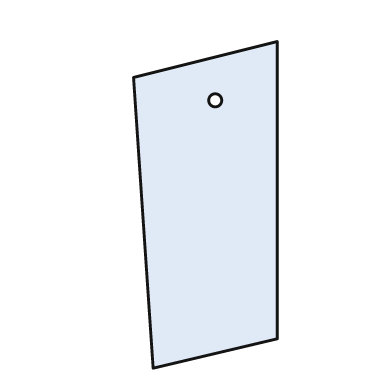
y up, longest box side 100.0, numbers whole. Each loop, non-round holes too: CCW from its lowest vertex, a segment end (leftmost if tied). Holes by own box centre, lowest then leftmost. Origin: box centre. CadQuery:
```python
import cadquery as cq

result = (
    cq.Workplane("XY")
    .moveTo(-16.0, -50.0)
    .lineTo(22.0, -41.0)
    .lineTo(22.0, 50.0)
    .lineTo(-22.0, 39.0)
    .close()
    .moveTo(3.0, 32.0)
    .circle(2.0)
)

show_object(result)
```